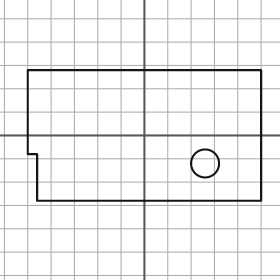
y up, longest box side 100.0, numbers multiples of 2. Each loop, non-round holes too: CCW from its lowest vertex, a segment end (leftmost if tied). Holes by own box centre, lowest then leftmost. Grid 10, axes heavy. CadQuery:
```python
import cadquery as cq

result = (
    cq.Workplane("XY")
    .moveTo(-46.0, -28.0)
    .lineTo(50.0, -28.0)
    .lineTo(50.0, 28.0)
    .lineTo(-50.0, 28.0)
    .lineTo(-50.0, -8.0)
    .lineTo(-46.0, -8.0)
    .close()
    .moveTo(26.0, -12.0)
    .circle(6.0)
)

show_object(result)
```